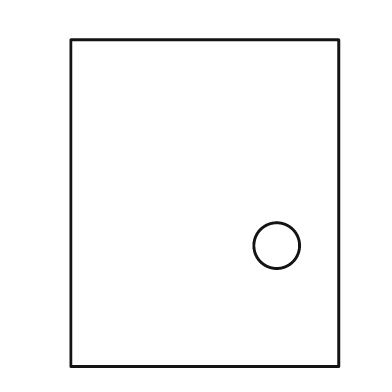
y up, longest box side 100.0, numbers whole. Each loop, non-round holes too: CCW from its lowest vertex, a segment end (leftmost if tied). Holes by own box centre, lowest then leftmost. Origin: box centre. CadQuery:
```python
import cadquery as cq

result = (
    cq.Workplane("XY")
    .moveTo(-41.0, -50.0)
    .lineTo(41.0, -50.0)
    .lineTo(41.0, 50.0)
    .lineTo(-41.0, 50.0)
    .close()
    .moveTo(22.0, -13.0)
    .circle(7.0)
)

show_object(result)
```